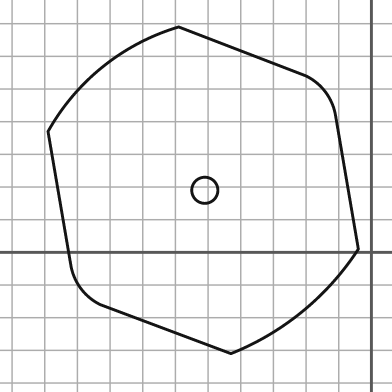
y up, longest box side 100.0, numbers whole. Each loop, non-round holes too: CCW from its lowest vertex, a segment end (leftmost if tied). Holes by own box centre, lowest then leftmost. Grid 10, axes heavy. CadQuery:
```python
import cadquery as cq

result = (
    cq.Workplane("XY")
    .moveTo(-43.0, -31.0)
    .threePointArc((-21.0, -18.0), (-4.0, 1.0))
    .lineTo(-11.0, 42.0)
    .threePointArc((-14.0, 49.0), (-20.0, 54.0))
    .lineTo(-59.0, 69.0)
    .threePointArc((-82.0, 57.0), (-99.0, 37.0))
    .lineTo(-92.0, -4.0)
    .threePointArc((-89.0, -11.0), (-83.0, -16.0))
    .close()
    .moveTo(-51.0, 19.0)
    .circle(4.0)
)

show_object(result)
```